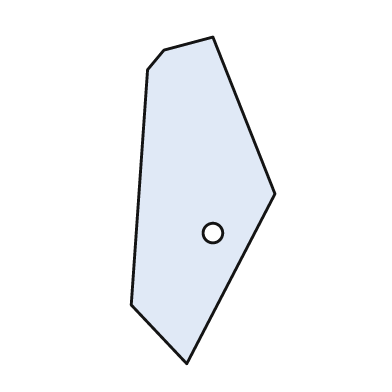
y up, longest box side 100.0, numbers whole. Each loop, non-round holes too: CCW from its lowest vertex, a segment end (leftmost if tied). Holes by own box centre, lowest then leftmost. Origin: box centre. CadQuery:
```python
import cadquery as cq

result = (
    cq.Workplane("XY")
    .moveTo(-5.0, -50.0)
    .lineTo(22.0, 2.0)
    .lineTo(3.0, 50.0)
    .lineTo(-12.0, 46.0)
    .lineTo(-17.0, 40.0)
    .lineTo(-22.0, -32.0)
    .close()
    .moveTo(3.0, -10.0)
    .circle(3.0)
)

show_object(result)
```